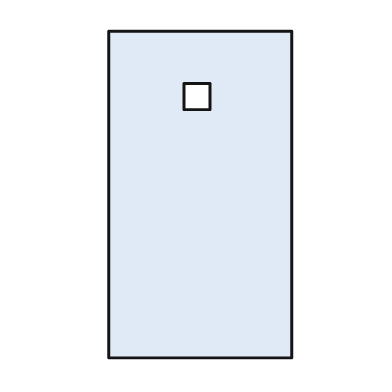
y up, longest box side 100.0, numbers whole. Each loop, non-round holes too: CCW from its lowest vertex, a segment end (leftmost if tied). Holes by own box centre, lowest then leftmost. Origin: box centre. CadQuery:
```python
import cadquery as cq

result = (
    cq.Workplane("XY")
    .moveTo(-28.0, -50.0)
    .lineTo(28.0, -50.0)
    .lineTo(28.0, 50.0)
    .lineTo(-28.0, 50.0)
    .close()
    .moveTo(-5.0, 26.0)
    .lineTo(3.0, 26.0)
    .lineTo(3.0, 34.0)
    .lineTo(-5.0, 34.0)
    .close()
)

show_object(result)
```